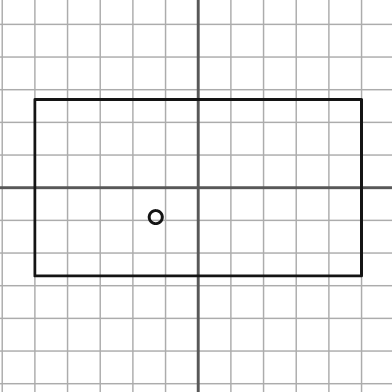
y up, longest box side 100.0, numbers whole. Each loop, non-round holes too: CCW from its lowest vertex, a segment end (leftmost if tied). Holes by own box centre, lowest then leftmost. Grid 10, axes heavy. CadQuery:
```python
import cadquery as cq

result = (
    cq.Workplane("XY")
    .moveTo(-50.0, -27.0)
    .lineTo(50.0, -27.0)
    .lineTo(50.0, 27.0)
    .lineTo(-50.0, 27.0)
    .close()
    .moveTo(-13.0, -9.0)
    .circle(2.0)
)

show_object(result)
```